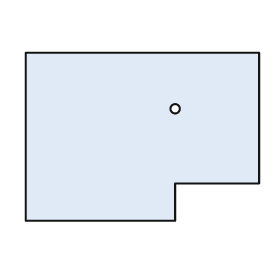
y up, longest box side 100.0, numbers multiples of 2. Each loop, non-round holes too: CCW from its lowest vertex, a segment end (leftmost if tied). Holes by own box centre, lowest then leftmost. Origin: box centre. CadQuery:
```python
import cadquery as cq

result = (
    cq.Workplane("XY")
    .moveTo(-50.0, -36.0)
    .lineTo(14.0, -36.0)
    .lineTo(14.0, -20.0)
    .lineTo(50.0, -20.0)
    .lineTo(50.0, 36.0)
    .lineTo(-50.0, 36.0)
    .close()
    .moveTo(14.0, 12.0)
    .circle(2.0)
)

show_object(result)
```